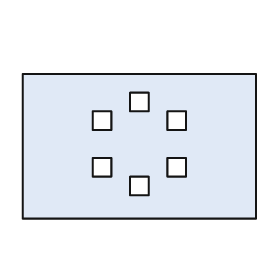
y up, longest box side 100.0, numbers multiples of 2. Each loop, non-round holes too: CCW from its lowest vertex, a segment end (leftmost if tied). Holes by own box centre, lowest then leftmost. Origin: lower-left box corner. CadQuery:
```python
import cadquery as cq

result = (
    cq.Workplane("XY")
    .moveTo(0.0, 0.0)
    .lineTo(100.0, 0.0)
    .lineTo(100.0, 62.0)
    .lineTo(0.0, 62.0)
    .close()
    .moveTo(46.0, 10.0)
    .lineTo(54.0, 10.0)
    .lineTo(54.0, 18.0)
    .lineTo(46.0, 18.0)
    .close()
    .moveTo(30.0, 18.0)
    .lineTo(38.0, 18.0)
    .lineTo(38.0, 26.0)
    .lineTo(30.0, 26.0)
    .close()
    .moveTo(62.0, 18.0)
    .lineTo(70.0, 18.0)
    .lineTo(70.0, 26.0)
    .lineTo(62.0, 26.0)
    .close()
    .moveTo(30.0, 38.0)
    .lineTo(38.0, 38.0)
    .lineTo(38.0, 46.0)
    .lineTo(30.0, 46.0)
    .close()
    .moveTo(62.0, 38.0)
    .lineTo(70.0, 38.0)
    .lineTo(70.0, 46.0)
    .lineTo(62.0, 46.0)
    .close()
    .moveTo(46.0, 46.0)
    .lineTo(54.0, 46.0)
    .lineTo(54.0, 54.0)
    .lineTo(46.0, 54.0)
    .close()
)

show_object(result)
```